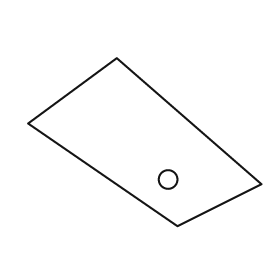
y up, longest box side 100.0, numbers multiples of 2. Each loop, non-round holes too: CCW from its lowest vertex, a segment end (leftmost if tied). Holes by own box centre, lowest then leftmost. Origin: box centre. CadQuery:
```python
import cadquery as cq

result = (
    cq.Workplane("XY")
    .moveTo(14.0, -36.0)
    .lineTo(50.0, -18.0)
    .lineTo(-12.0, 36.0)
    .lineTo(-50.0, 8.0)
    .close()
    .moveTo(10.0, -16.0)
    .circle(4.0)
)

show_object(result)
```